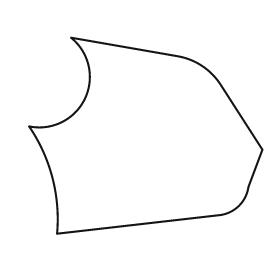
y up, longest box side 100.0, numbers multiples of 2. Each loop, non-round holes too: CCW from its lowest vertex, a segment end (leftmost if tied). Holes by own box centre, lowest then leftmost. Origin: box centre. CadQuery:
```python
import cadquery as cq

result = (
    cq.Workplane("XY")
    .moveTo(-38.0, -42.0)
    .lineTo(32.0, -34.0)
    .threePointArc((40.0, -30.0), (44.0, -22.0))
    .lineTo(50.0, -6.0)
    .lineTo(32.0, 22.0)
    .threePointArc((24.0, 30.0), (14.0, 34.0))
    .lineTo(-32.0, 42.0)
    .threePointArc((-26.0, 16.0), (-50.0, 4.0))
    .threePointArc((-40.0, -18.0), (-38.0, -42.0))
    .close()
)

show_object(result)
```